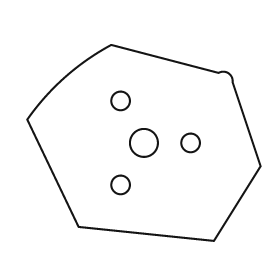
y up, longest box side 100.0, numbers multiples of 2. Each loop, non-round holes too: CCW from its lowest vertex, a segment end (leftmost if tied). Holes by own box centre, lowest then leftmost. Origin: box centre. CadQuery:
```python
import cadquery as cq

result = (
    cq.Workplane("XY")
    .moveTo(30.0, -42.0)
    .lineTo(50.0, -10.0)
    .lineTo(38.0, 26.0)
    .threePointArc((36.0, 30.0), (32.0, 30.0))
    .lineTo(-14.0, 42.0)
    .threePointArc((-34.0, 28.0), (-50.0, 10.0))
    .lineTo(-28.0, -36.0)
    .close()
    .moveTo(-10.0, -18.0)
    .circle(4.0)
    .moveTo(0.0, 0.0)
    .circle(6.0)
    .moveTo(20.0, 0.0)
    .circle(4.0)
    .moveTo(-10.0, 18.0)
    .circle(4.0)
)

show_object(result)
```